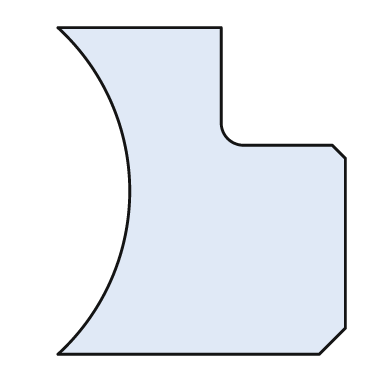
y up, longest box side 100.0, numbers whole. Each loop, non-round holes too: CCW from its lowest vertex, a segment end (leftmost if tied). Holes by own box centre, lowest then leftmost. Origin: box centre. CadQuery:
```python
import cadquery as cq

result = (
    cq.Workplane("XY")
    .moveTo(-44.0, -50.0)
    .lineTo(36.0, -50.0)
    .lineTo(44.0, -42.0)
    .lineTo(44.0, 10.0)
    .lineTo(40.0, 14.0)
    .lineTo(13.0, 14.0)
    .threePointArc((8.0, 16.0), (6.0, 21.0))
    .lineTo(6.0, 50.0)
    .lineTo(-44.0, 50.0)
    .threePointArc((-22.0, 0.0), (-44.0, -50.0))
    .close()
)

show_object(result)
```